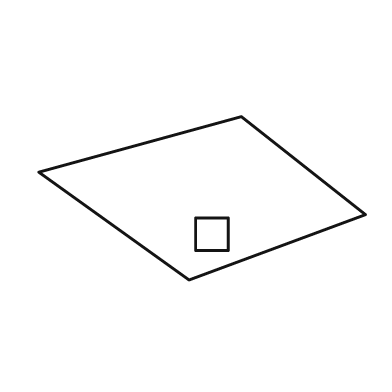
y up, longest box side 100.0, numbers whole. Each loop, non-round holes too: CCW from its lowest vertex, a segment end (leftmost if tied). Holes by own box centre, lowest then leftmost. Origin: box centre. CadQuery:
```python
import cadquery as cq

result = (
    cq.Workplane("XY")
    .moveTo(-4.0, -25.0)
    .lineTo(50.0, -5.0)
    .lineTo(12.0, 25.0)
    .lineTo(-50.0, 8.0)
    .close()
    .moveTo(-2.0, -16.0)
    .lineTo(8.0, -16.0)
    .lineTo(8.0, -6.0)
    .lineTo(-2.0, -6.0)
    .close()
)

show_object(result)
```